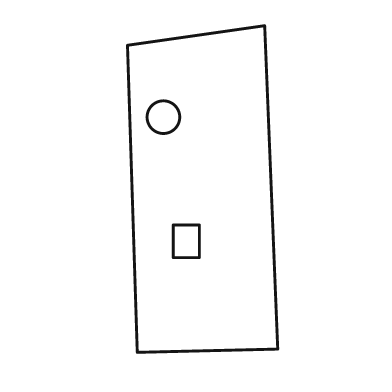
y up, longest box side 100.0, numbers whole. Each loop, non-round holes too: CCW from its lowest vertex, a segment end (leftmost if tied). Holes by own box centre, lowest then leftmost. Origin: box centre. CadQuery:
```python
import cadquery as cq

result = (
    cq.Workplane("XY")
    .moveTo(-20.0, -50.0)
    .lineTo(23.0, -49.0)
    .lineTo(19.0, 50.0)
    .lineTo(-23.0, 44.0)
    .close()
    .moveTo(-9.0, -21.0)
    .lineTo(-1.0, -21.0)
    .lineTo(-1.0, -11.0)
    .lineTo(-9.0, -11.0)
    .close()
    .moveTo(-12.0, 22.0)
    .circle(5.0)
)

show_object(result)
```